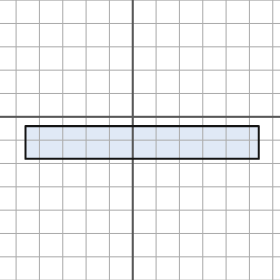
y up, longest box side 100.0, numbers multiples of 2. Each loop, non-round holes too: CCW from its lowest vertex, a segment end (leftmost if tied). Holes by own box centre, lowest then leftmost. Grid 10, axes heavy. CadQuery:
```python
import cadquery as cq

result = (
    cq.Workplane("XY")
    .moveTo(-46.0, -18.0)
    .lineTo(54.0, -18.0)
    .lineTo(54.0, -4.0)
    .lineTo(-46.0, -4.0)
    .close()
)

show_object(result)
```